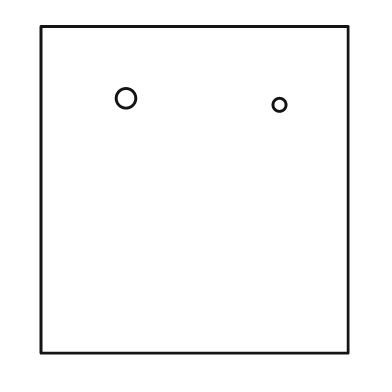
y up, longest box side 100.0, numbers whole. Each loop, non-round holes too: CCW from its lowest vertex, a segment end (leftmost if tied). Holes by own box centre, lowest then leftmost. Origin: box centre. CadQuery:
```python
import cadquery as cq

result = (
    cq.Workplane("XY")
    .moveTo(-47.0, -50.0)
    .lineTo(47.0, -50.0)
    .lineTo(47.0, 50.0)
    .lineTo(-47.0, 50.0)
    .close()
    .moveTo(26.0, 26.0)
    .circle(2.0)
    .moveTo(-21.0, 28.0)
    .circle(3.0)
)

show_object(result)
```